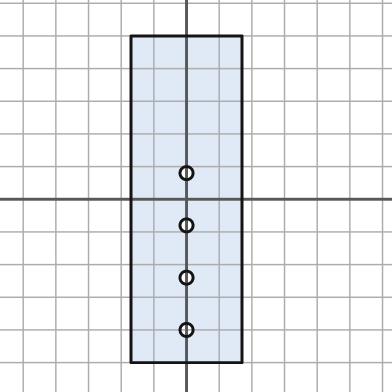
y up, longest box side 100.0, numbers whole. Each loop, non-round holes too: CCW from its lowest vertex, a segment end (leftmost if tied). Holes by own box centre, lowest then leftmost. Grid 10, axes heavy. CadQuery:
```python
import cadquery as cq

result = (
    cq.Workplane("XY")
    .moveTo(-17.0, -50.0)
    .lineTo(17.0, -50.0)
    .lineTo(17.0, 50.0)
    .lineTo(-17.0, 50.0)
    .close()
    .moveTo(0.0, -40.0)
    .circle(2.0)
    .moveTo(0.0, -24.0)
    .circle(2.0)
    .moveTo(0.0, -8.0)
    .circle(2.0)
    .moveTo(0.0, 8.0)
    .circle(2.0)
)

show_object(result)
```